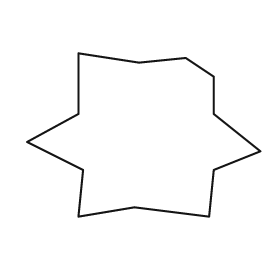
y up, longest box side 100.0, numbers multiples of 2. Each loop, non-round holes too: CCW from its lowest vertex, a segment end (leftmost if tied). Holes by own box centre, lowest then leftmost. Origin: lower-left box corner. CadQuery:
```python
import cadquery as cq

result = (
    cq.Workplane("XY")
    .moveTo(22.0, 0.0)
    .lineTo(46.0, 4.0)
    .lineTo(78.0, 0.0)
    .lineTo(80.0, 20.0)
    .lineTo(100.0, 28.0)
    .lineTo(80.0, 44.0)
    .lineTo(80.0, 60.0)
    .lineTo(68.0, 68.0)
    .lineTo(48.0, 66.0)
    .lineTo(22.0, 70.0)
    .lineTo(22.0, 44.0)
    .lineTo(0.0, 32.0)
    .lineTo(24.0, 20.0)
    .close()
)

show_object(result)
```